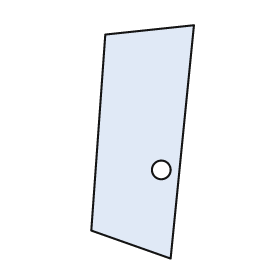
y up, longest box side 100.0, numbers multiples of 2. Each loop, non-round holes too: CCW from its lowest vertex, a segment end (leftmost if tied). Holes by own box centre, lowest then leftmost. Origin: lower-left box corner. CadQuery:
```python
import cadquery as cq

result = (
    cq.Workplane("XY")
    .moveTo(34.0, 0.0)
    .lineTo(44.0, 100.0)
    .lineTo(6.0, 96.0)
    .lineTo(0.0, 12.0)
    .close()
    .moveTo(30.0, 38.0)
    .circle(4.0)
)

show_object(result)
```